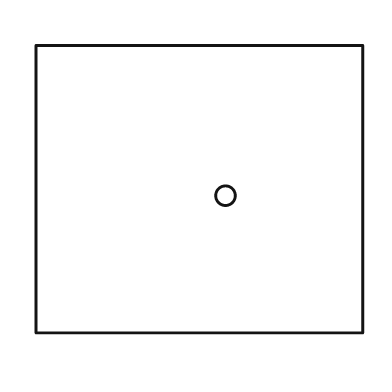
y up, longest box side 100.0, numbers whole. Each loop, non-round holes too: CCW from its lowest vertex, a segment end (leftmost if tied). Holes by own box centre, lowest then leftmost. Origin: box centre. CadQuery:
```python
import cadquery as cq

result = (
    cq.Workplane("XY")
    .moveTo(-50.0, -44.0)
    .lineTo(50.0, -44.0)
    .lineTo(50.0, 44.0)
    .lineTo(-50.0, 44.0)
    .close()
    .moveTo(8.0, -2.0)
    .circle(3.0)
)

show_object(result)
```